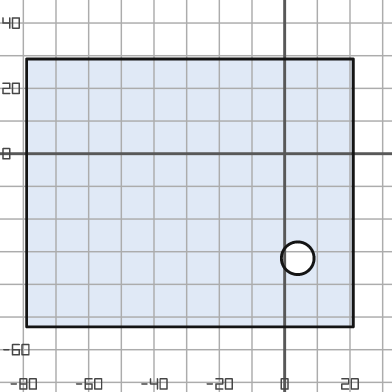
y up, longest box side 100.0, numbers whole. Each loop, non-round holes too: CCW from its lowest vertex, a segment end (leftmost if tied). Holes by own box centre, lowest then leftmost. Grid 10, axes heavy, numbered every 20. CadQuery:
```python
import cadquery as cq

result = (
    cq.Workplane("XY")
    .moveTo(-79.0, -53.0)
    .lineTo(21.0, -53.0)
    .lineTo(21.0, 29.0)
    .lineTo(-79.0, 29.0)
    .close()
    .moveTo(4.0, -32.0)
    .circle(5.0)
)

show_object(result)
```